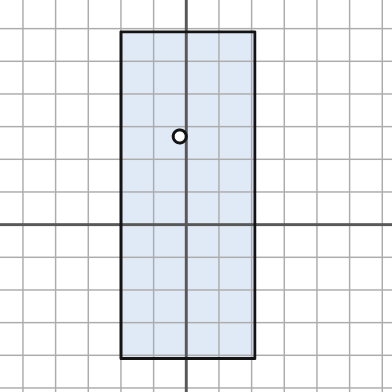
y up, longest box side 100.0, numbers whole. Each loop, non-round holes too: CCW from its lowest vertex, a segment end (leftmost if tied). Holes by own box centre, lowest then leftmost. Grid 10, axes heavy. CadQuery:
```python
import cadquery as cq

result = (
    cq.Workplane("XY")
    .moveTo(-20.0, -41.0)
    .lineTo(21.0, -41.0)
    .lineTo(21.0, 59.0)
    .lineTo(-20.0, 59.0)
    .close()
    .moveTo(-2.0, 27.0)
    .circle(2.0)
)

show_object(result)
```